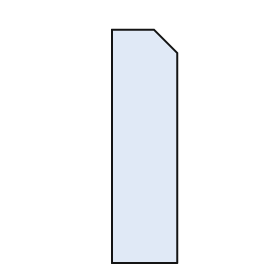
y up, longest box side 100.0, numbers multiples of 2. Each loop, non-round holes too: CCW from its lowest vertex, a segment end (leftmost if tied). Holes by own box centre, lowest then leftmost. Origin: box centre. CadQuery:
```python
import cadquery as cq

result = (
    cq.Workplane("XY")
    .moveTo(-14.0, -50.0)
    .lineTo(14.0, -50.0)
    .lineTo(14.0, 40.0)
    .lineTo(4.0, 50.0)
    .lineTo(-14.0, 50.0)
    .close()
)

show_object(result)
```